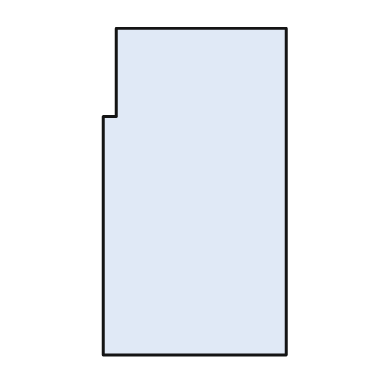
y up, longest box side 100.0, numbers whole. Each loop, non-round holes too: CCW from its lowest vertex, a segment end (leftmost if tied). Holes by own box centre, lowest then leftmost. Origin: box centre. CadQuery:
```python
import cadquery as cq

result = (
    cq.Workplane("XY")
    .moveTo(-28.0, -50.0)
    .lineTo(28.0, -50.0)
    .lineTo(28.0, 50.0)
    .lineTo(-24.0, 50.0)
    .lineTo(-24.0, 23.0)
    .lineTo(-28.0, 23.0)
    .close()
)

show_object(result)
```